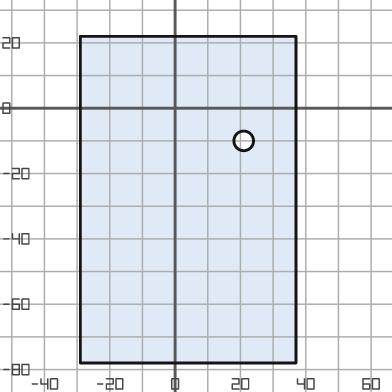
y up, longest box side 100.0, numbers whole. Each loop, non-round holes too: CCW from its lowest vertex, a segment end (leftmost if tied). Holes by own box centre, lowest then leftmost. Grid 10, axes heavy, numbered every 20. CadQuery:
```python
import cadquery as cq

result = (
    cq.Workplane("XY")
    .moveTo(-29.0, -78.0)
    .lineTo(37.0, -78.0)
    .lineTo(37.0, 22.0)
    .lineTo(-29.0, 22.0)
    .close()
    .moveTo(21.0, -10.0)
    .circle(3.0)
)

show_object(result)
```